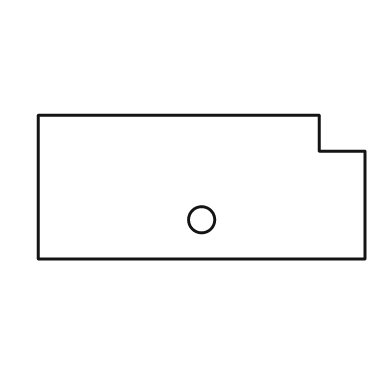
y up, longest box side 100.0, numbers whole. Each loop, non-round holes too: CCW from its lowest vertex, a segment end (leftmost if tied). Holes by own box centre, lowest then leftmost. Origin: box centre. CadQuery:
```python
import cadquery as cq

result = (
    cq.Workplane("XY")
    .moveTo(-50.0, -22.0)
    .lineTo(50.0, -22.0)
    .lineTo(50.0, 11.0)
    .lineTo(36.0, 11.0)
    .lineTo(36.0, 22.0)
    .lineTo(-50.0, 22.0)
    .close()
    .moveTo(0.0, -10.0)
    .circle(4.0)
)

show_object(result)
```